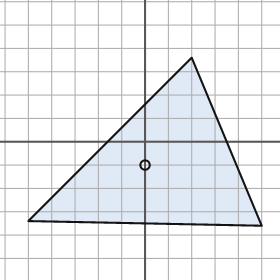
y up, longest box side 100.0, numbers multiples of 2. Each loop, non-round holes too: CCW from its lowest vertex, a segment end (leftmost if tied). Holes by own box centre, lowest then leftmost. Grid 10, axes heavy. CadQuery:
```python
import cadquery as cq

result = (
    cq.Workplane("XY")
    .moveTo(50.0, -36.0)
    .lineTo(20.0, 36.0)
    .lineTo(-50.0, -34.0)
    .close()
    .moveTo(0.0, -10.0)
    .circle(2.0)
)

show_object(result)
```